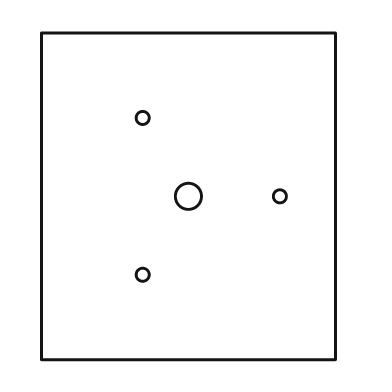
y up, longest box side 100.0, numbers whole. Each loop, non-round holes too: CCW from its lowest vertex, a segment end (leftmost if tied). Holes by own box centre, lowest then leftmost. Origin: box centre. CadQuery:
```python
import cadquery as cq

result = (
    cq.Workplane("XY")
    .moveTo(-45.0, -50.0)
    .lineTo(45.0, -50.0)
    .lineTo(45.0, 50.0)
    .lineTo(-45.0, 50.0)
    .close()
    .moveTo(-14.0, -24.0)
    .circle(2.0)
    .moveTo(0.0, 0.0)
    .circle(4.0)
    .moveTo(28.0, 0.0)
    .circle(2.0)
    .moveTo(-14.0, 24.0)
    .circle(2.0)
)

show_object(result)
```